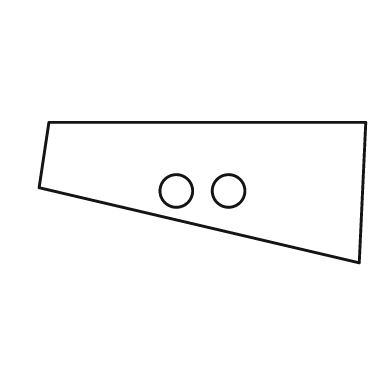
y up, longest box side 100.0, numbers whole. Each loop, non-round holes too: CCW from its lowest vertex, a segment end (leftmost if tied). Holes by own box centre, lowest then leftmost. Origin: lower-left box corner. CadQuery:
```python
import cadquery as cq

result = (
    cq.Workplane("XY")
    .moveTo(98.0, 0.0)
    .lineTo(100.0, 43.0)
    .lineTo(3.0, 43.0)
    .lineTo(0.0, 23.0)
    .close()
    .moveTo(42.0, 22.0)
    .circle(5.0)
    .moveTo(58.0, 22.0)
    .circle(5.0)
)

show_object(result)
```